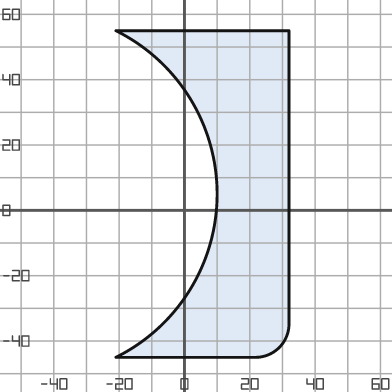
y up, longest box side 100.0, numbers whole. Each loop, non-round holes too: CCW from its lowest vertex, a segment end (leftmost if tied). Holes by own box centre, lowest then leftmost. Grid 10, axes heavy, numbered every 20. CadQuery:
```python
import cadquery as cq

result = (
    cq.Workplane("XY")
    .moveTo(-21.0, -45.0)
    .lineTo(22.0, -45.0)
    .threePointArc((29.0, -42.0), (32.0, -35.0))
    .lineTo(32.0, 55.0)
    .lineTo(-21.0, 55.0)
    .threePointArc((10.0, 5.0), (-21.0, -45.0))
    .close()
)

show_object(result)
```